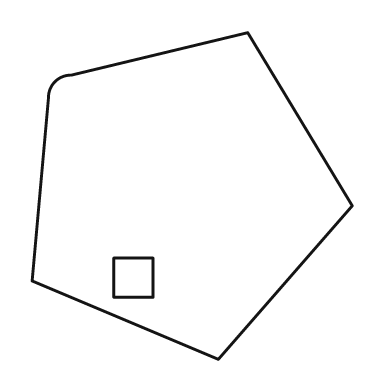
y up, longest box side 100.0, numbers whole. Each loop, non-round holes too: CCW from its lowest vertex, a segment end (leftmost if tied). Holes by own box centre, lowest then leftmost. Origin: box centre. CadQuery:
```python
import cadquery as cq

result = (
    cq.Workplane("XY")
    .moveTo(8.0, -50.0)
    .lineTo(49.0, -3.0)
    .lineTo(17.0, 50.0)
    .lineTo(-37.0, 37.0)
    .threePointArc((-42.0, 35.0), (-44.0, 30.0))
    .lineTo(-49.0, -26.0)
    .close()
    .moveTo(-24.0, -31.0)
    .lineTo(-12.0, -31.0)
    .lineTo(-12.0, -19.0)
    .lineTo(-24.0, -19.0)
    .close()
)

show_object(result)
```